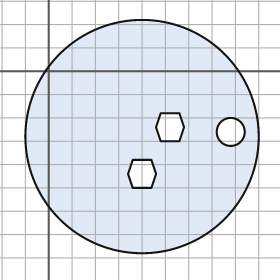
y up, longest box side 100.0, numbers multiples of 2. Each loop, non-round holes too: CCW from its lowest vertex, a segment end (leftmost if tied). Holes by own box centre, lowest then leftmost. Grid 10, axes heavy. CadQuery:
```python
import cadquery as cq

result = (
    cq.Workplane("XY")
    .moveTo(40.0, -28.0)
    .circle(50.0)
    .moveTo(36.0, -50.0)
    .lineTo(44.0, -50.0)
    .lineTo(46.0, -44.0)
    .lineTo(44.0, -38.0)
    .lineTo(36.0, -38.0)
    .lineTo(34.0, -44.0)
    .close()
    .moveTo(78.0, -26.0)
    .circle(6.0)
    .moveTo(48.0, -30.0)
    .lineTo(56.0, -30.0)
    .lineTo(58.0, -24.0)
    .lineTo(56.0, -18.0)
    .lineTo(48.0, -18.0)
    .lineTo(46.0, -24.0)
    .close()
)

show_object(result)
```